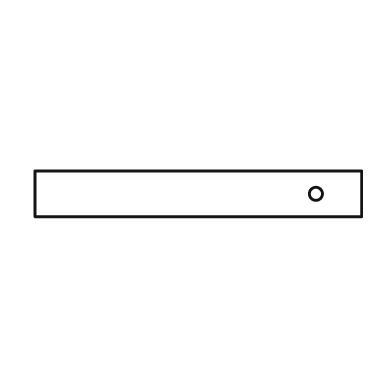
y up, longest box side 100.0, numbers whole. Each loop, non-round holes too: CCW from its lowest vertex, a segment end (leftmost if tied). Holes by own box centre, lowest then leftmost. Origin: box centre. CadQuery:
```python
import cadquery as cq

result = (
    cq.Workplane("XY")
    .moveTo(-50.0, -7.0)
    .lineTo(50.0, -7.0)
    .lineTo(50.0, 7.0)
    .lineTo(-50.0, 7.0)
    .close()
    .moveTo(36.0, 0.0)
    .circle(2.0)
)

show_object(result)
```